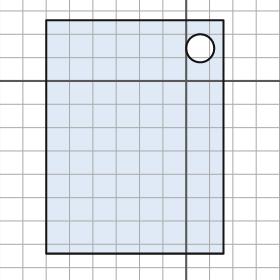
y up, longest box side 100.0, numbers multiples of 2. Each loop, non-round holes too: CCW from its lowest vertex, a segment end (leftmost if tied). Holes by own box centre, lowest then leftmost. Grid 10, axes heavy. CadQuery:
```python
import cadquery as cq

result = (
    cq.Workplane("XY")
    .moveTo(-60.0, -74.0)
    .lineTo(16.0, -74.0)
    .lineTo(16.0, 26.0)
    .lineTo(-60.0, 26.0)
    .close()
    .moveTo(6.0, 14.0)
    .circle(6.0)
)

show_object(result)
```